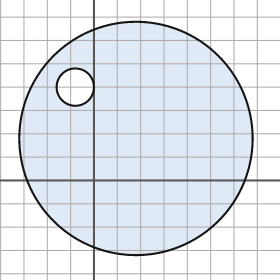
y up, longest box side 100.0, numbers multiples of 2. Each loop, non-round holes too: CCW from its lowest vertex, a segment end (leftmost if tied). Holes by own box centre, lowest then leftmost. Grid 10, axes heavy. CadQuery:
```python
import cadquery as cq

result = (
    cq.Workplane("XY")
    .moveTo(18.0, 18.0)
    .circle(50.0)
    .moveTo(-8.0, 40.0)
    .circle(8.0)
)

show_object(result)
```